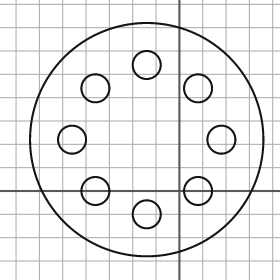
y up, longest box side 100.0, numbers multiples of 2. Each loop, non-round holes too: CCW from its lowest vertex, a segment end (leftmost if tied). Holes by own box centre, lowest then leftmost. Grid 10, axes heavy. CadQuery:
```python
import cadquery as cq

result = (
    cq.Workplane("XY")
    .moveTo(-14.0, 22.0)
    .circle(50.0)
    .moveTo(-14.0, -10.0)
    .circle(6.0)
    .moveTo(-36.0, 0.0)
    .circle(6.0)
    .moveTo(8.0, 0.0)
    .circle(6.0)
    .moveTo(-46.0, 22.0)
    .circle(6.0)
    .moveTo(18.0, 22.0)
    .circle(6.0)
    .moveTo(-36.0, 44.0)
    .circle(6.0)
    .moveTo(8.0, 44.0)
    .circle(6.0)
    .moveTo(-14.0, 54.0)
    .circle(6.0)
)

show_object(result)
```